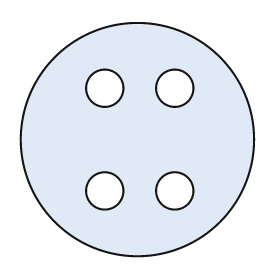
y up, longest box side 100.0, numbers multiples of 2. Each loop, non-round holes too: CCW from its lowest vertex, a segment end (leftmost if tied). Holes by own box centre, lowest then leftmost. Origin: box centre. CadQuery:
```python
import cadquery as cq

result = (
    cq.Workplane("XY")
    .moveTo(0.0, 0.0)
    .circle(50.0)
    .moveTo(-14.0, -22.0)
    .circle(8.0)
    .moveTo(16.0, -22.0)
    .circle(8.0)
    .moveTo(-14.0, 22.0)
    .circle(8.0)
    .moveTo(16.0, 22.0)
    .circle(8.0)
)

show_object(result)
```